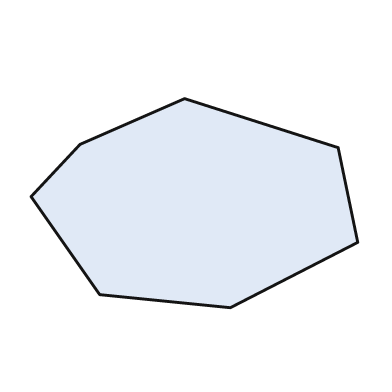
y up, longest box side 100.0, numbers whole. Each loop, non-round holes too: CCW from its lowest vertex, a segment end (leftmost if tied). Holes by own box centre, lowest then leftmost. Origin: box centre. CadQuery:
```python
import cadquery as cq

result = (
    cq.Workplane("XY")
    .moveTo(11.0, -32.0)
    .lineTo(50.0, -12.0)
    .lineTo(44.0, 17.0)
    .lineTo(-3.0, 32.0)
    .lineTo(-35.0, 18.0)
    .lineTo(-50.0, 2.0)
    .lineTo(-29.0, -28.0)
    .close()
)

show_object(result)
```